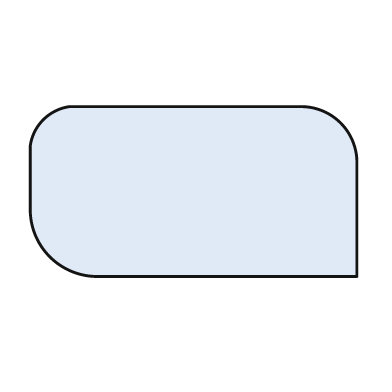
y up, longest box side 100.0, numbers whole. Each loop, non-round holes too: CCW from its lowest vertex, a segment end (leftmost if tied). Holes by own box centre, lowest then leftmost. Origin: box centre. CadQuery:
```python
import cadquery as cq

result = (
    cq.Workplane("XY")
    .moveTo(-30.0, -26.0)
    .lineTo(50.0, -26.0)
    .lineTo(50.0, 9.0)
    .threePointArc((45.0, 21.0), (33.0, 26.0))
    .lineTo(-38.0, 26.0)
    .threePointArc((-46.0, 22.0), (-50.0, 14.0))
    .lineTo(-50.0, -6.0)
    .threePointArc((-44.0, -20.0), (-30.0, -26.0))
    .close()
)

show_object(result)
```